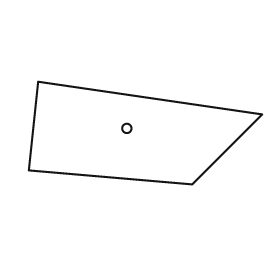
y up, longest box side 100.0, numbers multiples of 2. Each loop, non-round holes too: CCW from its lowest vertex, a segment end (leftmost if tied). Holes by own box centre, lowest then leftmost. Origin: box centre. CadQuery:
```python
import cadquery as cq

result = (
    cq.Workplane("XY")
    .moveTo(20.0, -22.0)
    .lineTo(50.0, 8.0)
    .lineTo(-46.0, 22.0)
    .lineTo(-50.0, -16.0)
    .close()
    .moveTo(-8.0, 2.0)
    .circle(2.0)
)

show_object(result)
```